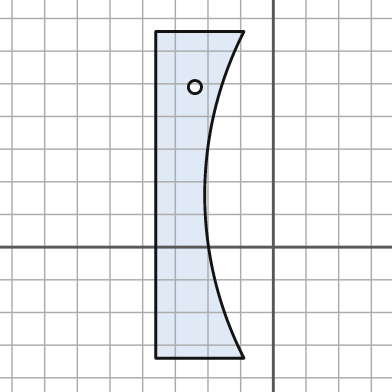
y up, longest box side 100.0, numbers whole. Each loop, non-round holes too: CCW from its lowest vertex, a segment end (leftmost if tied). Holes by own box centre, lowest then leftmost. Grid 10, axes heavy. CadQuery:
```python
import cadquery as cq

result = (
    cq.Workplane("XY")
    .moveTo(-36.0, -34.0)
    .lineTo(-9.0, -34.0)
    .threePointArc((-21.0, 16.0), (-9.0, 66.0))
    .lineTo(-36.0, 66.0)
    .close()
    .moveTo(-24.0, 49.0)
    .circle(2.0)
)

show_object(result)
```